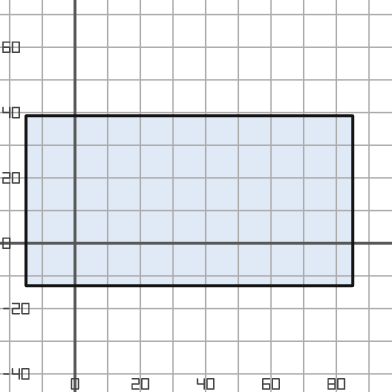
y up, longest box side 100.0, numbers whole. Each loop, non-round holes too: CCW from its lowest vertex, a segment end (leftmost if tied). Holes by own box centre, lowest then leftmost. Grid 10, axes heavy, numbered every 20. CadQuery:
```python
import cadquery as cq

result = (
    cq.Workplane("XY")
    .moveTo(-15.0, -13.0)
    .lineTo(85.0, -13.0)
    .lineTo(85.0, 39.0)
    .lineTo(-15.0, 39.0)
    .close()
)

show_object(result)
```